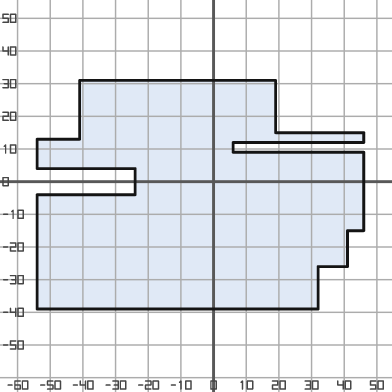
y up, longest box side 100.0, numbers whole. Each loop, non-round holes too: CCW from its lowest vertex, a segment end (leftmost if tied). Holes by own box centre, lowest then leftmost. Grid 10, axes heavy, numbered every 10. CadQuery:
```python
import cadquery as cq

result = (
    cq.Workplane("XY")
    .moveTo(-54.0, -39.0)
    .lineTo(32.0, -39.0)
    .lineTo(32.0, -26.0)
    .lineTo(41.0, -26.0)
    .lineTo(41.0, -15.0)
    .lineTo(46.0, -15.0)
    .lineTo(46.0, 9.0)
    .lineTo(6.0, 9.0)
    .lineTo(6.0, 12.0)
    .lineTo(46.0, 12.0)
    .lineTo(46.0, 15.0)
    .lineTo(19.0, 15.0)
    .lineTo(19.0, 31.0)
    .lineTo(-41.0, 31.0)
    .lineTo(-41.0, 13.0)
    .lineTo(-54.0, 13.0)
    .lineTo(-54.0, 4.0)
    .lineTo(-24.0, 4.0)
    .lineTo(-24.0, -4.0)
    .lineTo(-54.0, -4.0)
    .close()
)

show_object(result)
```